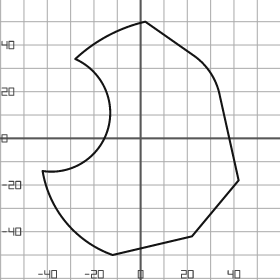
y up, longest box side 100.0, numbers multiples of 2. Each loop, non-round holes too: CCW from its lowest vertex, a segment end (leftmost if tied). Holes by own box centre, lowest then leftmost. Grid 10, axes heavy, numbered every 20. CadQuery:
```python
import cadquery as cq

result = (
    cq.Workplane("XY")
    .moveTo(-12.0, -50.0)
    .lineTo(22.0, -42.0)
    .lineTo(42.0, -18.0)
    .lineTo(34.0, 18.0)
    .threePointArc((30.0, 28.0), (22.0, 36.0))
    .lineTo(2.0, 50.0)
    .threePointArc((-14.0, 44.0), (-28.0, 34.0))
    .threePointArc((-14.0, 4.0), (-42.0, -14.0))
    .threePointArc((-32.0, -36.0), (-12.0, -50.0))
    .close()
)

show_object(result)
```